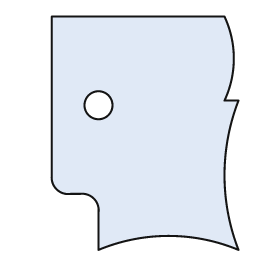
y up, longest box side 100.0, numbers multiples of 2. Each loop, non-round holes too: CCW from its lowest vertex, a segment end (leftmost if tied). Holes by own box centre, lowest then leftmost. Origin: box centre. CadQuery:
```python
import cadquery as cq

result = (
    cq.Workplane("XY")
    .moveTo(-20.0, -50.0)
    .threePointArc((10.0, -44.0), (40.0, -50.0))
    .threePointArc((34.0, -18.0), (40.0, 14.0))
    .lineTo(34.0, 14.0)
    .threePointArc((38.0, 32.0), (34.0, 50.0))
    .lineTo(-40.0, 50.0)
    .lineTo(-40.0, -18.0)
    .threePointArc((-38.0, -24.0), (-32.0, -26.0))
    .lineTo(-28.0, -26.0)
    .threePointArc((-22.0, -28.0), (-20.0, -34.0))
    .close()
    .moveTo(-20.0, 12.0)
    .circle(6.0)
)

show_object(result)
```